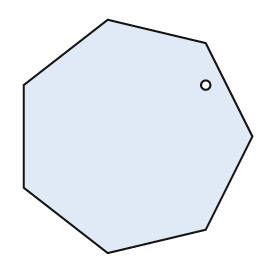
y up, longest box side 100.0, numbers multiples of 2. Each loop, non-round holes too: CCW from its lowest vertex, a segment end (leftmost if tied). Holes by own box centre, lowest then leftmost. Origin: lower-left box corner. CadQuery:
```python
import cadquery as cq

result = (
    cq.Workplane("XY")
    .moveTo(36.0, 0.0)
    .lineTo(78.0, 10.0)
    .lineTo(98.0, 50.0)
    .lineTo(78.0, 90.0)
    .lineTo(36.0, 100.0)
    .lineTo(0.0, 72.0)
    .lineTo(0.0, 28.0)
    .close()
    .moveTo(78.0, 72.0)
    .circle(2.0)
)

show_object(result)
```